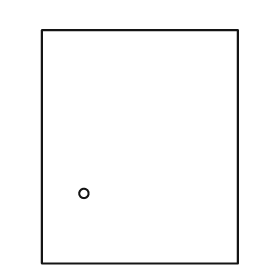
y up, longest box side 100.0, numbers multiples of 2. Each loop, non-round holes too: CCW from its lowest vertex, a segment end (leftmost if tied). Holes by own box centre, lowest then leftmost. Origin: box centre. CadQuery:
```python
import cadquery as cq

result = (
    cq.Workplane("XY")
    .moveTo(-42.0, -50.0)
    .lineTo(42.0, -50.0)
    .lineTo(42.0, 50.0)
    .lineTo(-42.0, 50.0)
    .close()
    .moveTo(-24.0, -20.0)
    .circle(2.0)
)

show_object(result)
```